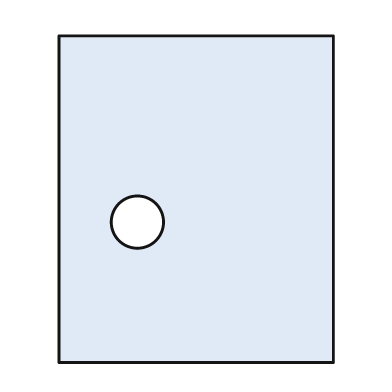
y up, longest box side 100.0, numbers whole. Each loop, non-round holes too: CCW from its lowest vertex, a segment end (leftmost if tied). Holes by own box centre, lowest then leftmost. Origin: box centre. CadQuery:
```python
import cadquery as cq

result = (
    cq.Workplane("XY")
    .moveTo(-42.0, -50.0)
    .lineTo(42.0, -50.0)
    .lineTo(42.0, 50.0)
    .lineTo(-42.0, 50.0)
    .close()
    .moveTo(-18.0, -7.0)
    .circle(8.0)
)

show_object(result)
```